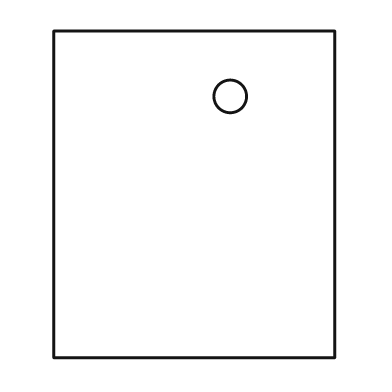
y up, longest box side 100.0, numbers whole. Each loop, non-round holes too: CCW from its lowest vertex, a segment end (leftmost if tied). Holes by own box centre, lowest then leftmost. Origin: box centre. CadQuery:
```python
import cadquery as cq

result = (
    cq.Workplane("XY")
    .moveTo(-43.0, -50.0)
    .lineTo(43.0, -50.0)
    .lineTo(43.0, 50.0)
    .lineTo(-43.0, 50.0)
    .close()
    .moveTo(11.0, 30.0)
    .circle(5.0)
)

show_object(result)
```